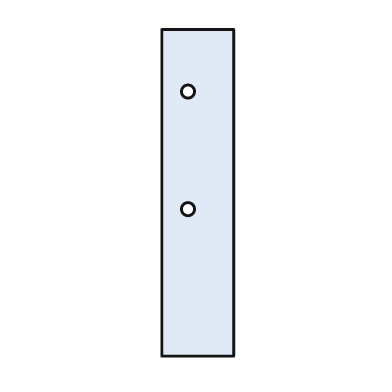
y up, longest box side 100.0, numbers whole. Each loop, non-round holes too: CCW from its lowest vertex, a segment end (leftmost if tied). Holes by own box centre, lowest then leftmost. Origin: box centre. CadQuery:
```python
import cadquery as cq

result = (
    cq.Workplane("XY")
    .moveTo(-11.0, -50.0)
    .lineTo(11.0, -50.0)
    .lineTo(11.0, 50.0)
    .lineTo(-11.0, 50.0)
    .close()
    .moveTo(-3.0, -5.0)
    .circle(2.0)
    .moveTo(-3.0, 31.0)
    .circle(2.0)
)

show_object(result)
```